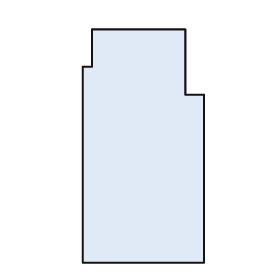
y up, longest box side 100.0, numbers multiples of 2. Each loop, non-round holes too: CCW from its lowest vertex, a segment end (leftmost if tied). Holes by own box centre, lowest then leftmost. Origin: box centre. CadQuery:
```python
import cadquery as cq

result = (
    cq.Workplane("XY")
    .moveTo(-26.0, -50.0)
    .lineTo(26.0, -50.0)
    .lineTo(26.0, 22.0)
    .lineTo(18.0, 22.0)
    .lineTo(18.0, 50.0)
    .lineTo(-22.0, 50.0)
    .lineTo(-22.0, 34.0)
    .lineTo(-26.0, 34.0)
    .close()
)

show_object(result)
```